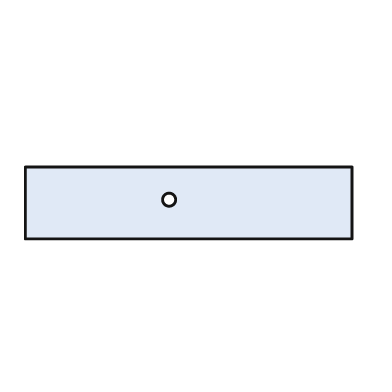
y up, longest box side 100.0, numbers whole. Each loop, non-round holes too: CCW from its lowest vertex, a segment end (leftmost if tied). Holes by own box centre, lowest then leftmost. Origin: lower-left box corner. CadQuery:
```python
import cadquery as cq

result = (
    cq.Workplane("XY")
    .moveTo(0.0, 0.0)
    .lineTo(100.0, 0.0)
    .lineTo(100.0, 22.0)
    .lineTo(0.0, 22.0)
    .close()
    .moveTo(44.0, 12.0)
    .circle(2.0)
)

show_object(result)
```